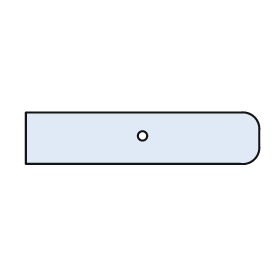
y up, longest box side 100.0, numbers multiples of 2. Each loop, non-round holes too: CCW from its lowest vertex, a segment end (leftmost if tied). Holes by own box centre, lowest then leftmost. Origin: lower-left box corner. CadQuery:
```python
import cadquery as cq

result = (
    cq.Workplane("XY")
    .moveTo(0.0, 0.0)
    .lineTo(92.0, 0.0)
    .threePointArc((98.0, 2.0), (100.0, 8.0))
    .lineTo(100.0, 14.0)
    .threePointArc((98.0, 20.0), (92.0, 22.0))
    .lineTo(0.0, 22.0)
    .close()
    .moveTo(50.0, 12.0)
    .circle(2.0)
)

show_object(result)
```